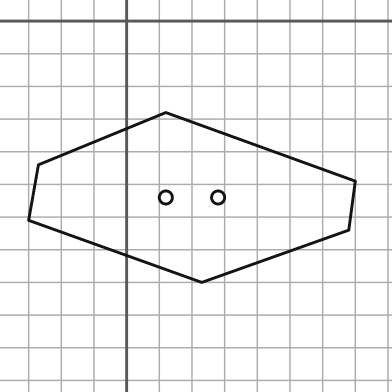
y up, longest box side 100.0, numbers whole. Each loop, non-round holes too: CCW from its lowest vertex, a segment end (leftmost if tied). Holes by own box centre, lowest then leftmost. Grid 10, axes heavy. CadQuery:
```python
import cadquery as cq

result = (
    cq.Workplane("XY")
    .moveTo(23.0, -80.0)
    .lineTo(68.0, -64.0)
    .lineTo(70.0, -49.0)
    .lineTo(12.0, -28.0)
    .lineTo(-27.0, -44.0)
    .lineTo(-30.0, -61.0)
    .close()
    .moveTo(12.0, -54.0)
    .circle(2.0)
    .moveTo(28.0, -54.0)
    .circle(2.0)
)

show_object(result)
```